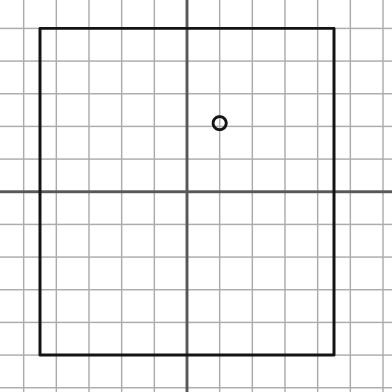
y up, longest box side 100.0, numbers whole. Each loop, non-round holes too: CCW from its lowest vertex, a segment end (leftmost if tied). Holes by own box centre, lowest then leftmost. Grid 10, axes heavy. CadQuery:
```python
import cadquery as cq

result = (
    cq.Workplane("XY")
    .moveTo(-45.0, -50.0)
    .lineTo(45.0, -50.0)
    .lineTo(45.0, 50.0)
    .lineTo(-45.0, 50.0)
    .close()
    .moveTo(10.0, 21.0)
    .circle(2.0)
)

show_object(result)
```